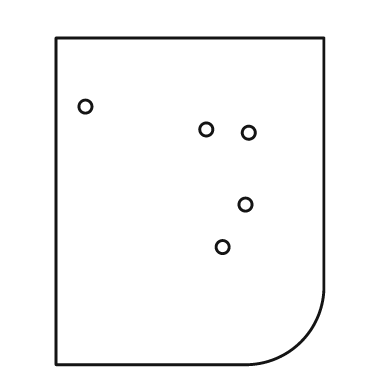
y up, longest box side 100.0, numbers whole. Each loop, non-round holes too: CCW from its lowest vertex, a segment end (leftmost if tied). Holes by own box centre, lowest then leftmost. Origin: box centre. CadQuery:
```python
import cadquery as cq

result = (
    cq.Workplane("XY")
    .moveTo(-41.0, -50.0)
    .lineTo(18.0, -50.0)
    .threePointArc((34.0, -43.0), (41.0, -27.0))
    .lineTo(41.0, 50.0)
    .lineTo(-41.0, 50.0)
    .close()
    .moveTo(10.0, -14.0)
    .circle(2.0)
    .moveTo(17.0, -1.0)
    .circle(2.0)
    .moveTo(18.0, 21.0)
    .circle(2.0)
    .moveTo(5.0, 22.0)
    .circle(2.0)
    .moveTo(-32.0, 29.0)
    .circle(2.0)
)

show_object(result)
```